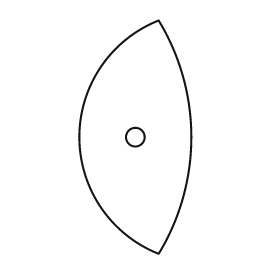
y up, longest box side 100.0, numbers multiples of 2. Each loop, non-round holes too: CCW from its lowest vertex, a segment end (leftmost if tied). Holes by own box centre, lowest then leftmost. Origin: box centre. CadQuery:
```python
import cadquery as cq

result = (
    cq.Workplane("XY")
    .moveTo(10.0, -50.0)
    .threePointArc((24.0, 0.0), (10.0, 50.0))
    .threePointArc((-24.0, 0.0), (10.0, -50.0))
    .close()
    .moveTo(0.0, 0.0)
    .circle(4.0)
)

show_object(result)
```